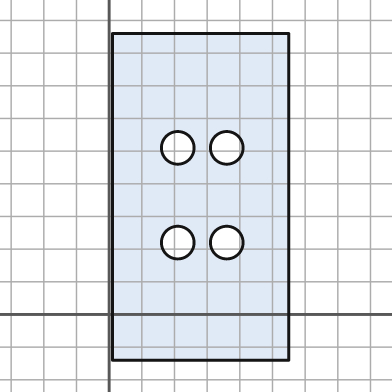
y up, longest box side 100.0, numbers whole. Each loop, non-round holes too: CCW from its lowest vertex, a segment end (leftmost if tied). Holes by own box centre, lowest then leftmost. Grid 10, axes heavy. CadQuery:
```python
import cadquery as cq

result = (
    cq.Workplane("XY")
    .moveTo(1.0, -14.0)
    .lineTo(55.0, -14.0)
    .lineTo(55.0, 86.0)
    .lineTo(1.0, 86.0)
    .close()
    .moveTo(21.0, 22.0)
    .circle(5.0)
    .moveTo(36.0, 22.0)
    .circle(5.0)
    .moveTo(21.0, 51.0)
    .circle(5.0)
    .moveTo(36.0, 51.0)
    .circle(5.0)
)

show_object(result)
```